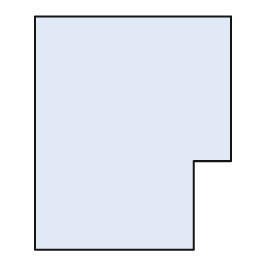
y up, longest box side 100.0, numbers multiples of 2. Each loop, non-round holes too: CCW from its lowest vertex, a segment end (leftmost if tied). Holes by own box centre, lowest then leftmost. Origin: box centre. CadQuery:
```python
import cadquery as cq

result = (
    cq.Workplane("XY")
    .moveTo(-42.0, -50.0)
    .lineTo(26.0, -50.0)
    .lineTo(26.0, -12.0)
    .lineTo(42.0, -12.0)
    .lineTo(42.0, 50.0)
    .lineTo(-42.0, 50.0)
    .close()
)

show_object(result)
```